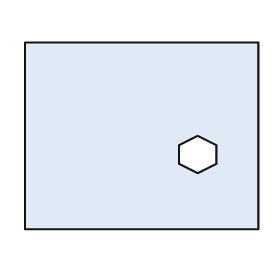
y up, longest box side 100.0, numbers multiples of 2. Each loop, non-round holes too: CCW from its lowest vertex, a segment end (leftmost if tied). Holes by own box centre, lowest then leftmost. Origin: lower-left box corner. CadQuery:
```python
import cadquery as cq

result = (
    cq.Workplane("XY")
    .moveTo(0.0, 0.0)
    .lineTo(100.0, 0.0)
    .lineTo(100.0, 80.0)
    .lineTo(0.0, 80.0)
    .close()
    .moveTo(74.0, 24.0)
    .lineTo(82.0, 28.0)
    .lineTo(82.0, 36.0)
    .lineTo(74.0, 40.0)
    .lineTo(66.0, 36.0)
    .lineTo(66.0, 28.0)
    .close()
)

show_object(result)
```